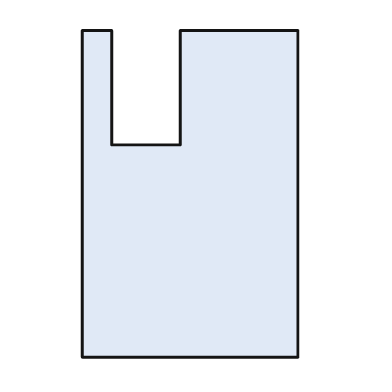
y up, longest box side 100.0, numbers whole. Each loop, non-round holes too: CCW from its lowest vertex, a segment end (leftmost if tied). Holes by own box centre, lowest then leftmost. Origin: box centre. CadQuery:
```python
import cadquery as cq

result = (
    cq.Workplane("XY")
    .moveTo(-33.0, -50.0)
    .lineTo(33.0, -50.0)
    .lineTo(33.0, 50.0)
    .lineTo(-3.0, 50.0)
    .lineTo(-3.0, 15.0)
    .lineTo(-24.0, 15.0)
    .lineTo(-24.0, 50.0)
    .lineTo(-33.0, 50.0)
    .close()
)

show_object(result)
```